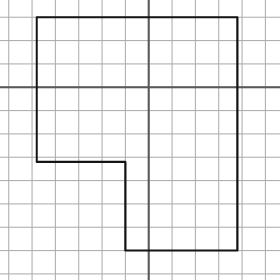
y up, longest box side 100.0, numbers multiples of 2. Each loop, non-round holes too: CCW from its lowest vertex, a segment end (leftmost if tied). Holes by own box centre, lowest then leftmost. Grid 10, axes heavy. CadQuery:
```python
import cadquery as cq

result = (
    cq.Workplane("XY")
    .moveTo(-10.0, -70.0)
    .lineTo(38.0, -70.0)
    .lineTo(38.0, 30.0)
    .lineTo(-48.0, 30.0)
    .lineTo(-48.0, -32.0)
    .lineTo(-10.0, -32.0)
    .close()
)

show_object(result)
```